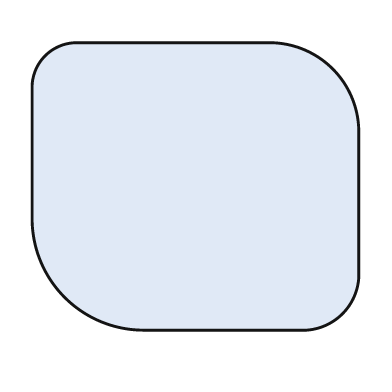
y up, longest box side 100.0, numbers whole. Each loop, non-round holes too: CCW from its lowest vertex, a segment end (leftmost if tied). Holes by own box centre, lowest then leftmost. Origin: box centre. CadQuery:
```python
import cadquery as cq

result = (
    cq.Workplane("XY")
    .moveTo(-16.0, -44.0)
    .lineTo(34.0, -44.0)
    .threePointArc((45.0, -39.0), (50.0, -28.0))
    .lineTo(50.0, 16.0)
    .threePointArc((42.0, 36.0), (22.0, 44.0))
    .lineTo(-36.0, 44.0)
    .threePointArc((-46.0, 40.0), (-50.0, 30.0))
    .lineTo(-50.0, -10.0)
    .threePointArc((-40.0, -34.0), (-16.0, -44.0))
    .close()
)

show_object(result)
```